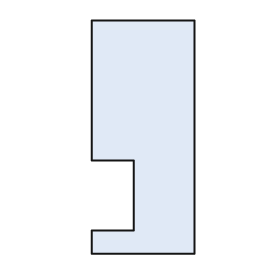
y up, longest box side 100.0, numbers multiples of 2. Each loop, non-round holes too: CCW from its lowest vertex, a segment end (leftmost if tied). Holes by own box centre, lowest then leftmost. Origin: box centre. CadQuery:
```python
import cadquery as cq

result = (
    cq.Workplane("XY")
    .moveTo(-22.0, -50.0)
    .lineTo(22.0, -50.0)
    .lineTo(22.0, 50.0)
    .lineTo(-22.0, 50.0)
    .lineTo(-22.0, -10.0)
    .lineTo(-4.0, -10.0)
    .lineTo(-4.0, -40.0)
    .lineTo(-22.0, -40.0)
    .close()
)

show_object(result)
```